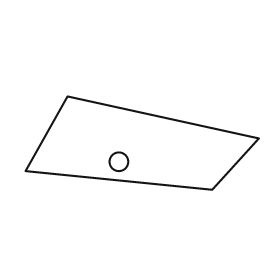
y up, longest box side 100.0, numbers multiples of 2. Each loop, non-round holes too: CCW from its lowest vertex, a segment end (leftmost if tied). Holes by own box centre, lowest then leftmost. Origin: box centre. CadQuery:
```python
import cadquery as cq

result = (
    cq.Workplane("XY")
    .moveTo(30.0, -20.0)
    .lineTo(50.0, 2.0)
    .lineTo(-32.0, 20.0)
    .lineTo(-50.0, -12.0)
    .close()
    .moveTo(-10.0, -8.0)
    .circle(4.0)
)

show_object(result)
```